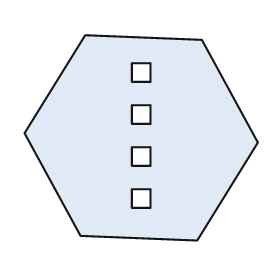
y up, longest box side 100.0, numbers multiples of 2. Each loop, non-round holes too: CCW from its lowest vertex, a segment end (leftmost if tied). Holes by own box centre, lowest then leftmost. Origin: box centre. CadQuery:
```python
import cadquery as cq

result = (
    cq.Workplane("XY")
    .moveTo(24.0, -44.0)
    .lineTo(50.0, -2.0)
    .lineTo(26.0, 42.0)
    .lineTo(-24.0, 44.0)
    .lineTo(-50.0, 2.0)
    .lineTo(-26.0, -42.0)
    .close()
    .moveTo(-4.0, -30.0)
    .lineTo(4.0, -30.0)
    .lineTo(4.0, -22.0)
    .lineTo(-4.0, -22.0)
    .close()
    .moveTo(-4.0, -12.0)
    .lineTo(4.0, -12.0)
    .lineTo(4.0, -4.0)
    .lineTo(-4.0, -4.0)
    .close()
    .moveTo(-4.0, 6.0)
    .lineTo(4.0, 6.0)
    .lineTo(4.0, 14.0)
    .lineTo(-4.0, 14.0)
    .close()
    .moveTo(-4.0, 24.0)
    .lineTo(4.0, 24.0)
    .lineTo(4.0, 32.0)
    .lineTo(-4.0, 32.0)
    .close()
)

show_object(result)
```